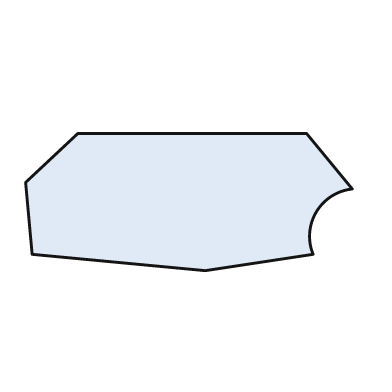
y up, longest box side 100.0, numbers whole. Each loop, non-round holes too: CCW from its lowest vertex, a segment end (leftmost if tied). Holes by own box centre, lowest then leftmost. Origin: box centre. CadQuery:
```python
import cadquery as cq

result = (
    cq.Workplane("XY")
    .moveTo(5.0, -21.0)
    .lineTo(38.0, -16.0)
    .threePointArc((39.0, -3.0), (50.0, 4.0))
    .lineTo(36.0, 21.0)
    .lineTo(-34.0, 21.0)
    .lineTo(-50.0, 6.0)
    .lineTo(-48.0, -16.0)
    .close()
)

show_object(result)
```